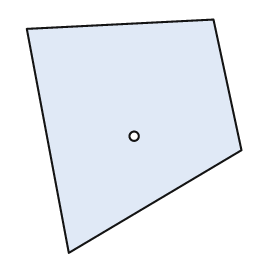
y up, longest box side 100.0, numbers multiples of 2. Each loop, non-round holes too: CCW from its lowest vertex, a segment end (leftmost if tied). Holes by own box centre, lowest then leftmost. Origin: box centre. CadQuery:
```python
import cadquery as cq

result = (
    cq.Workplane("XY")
    .moveTo(-28.0, -50.0)
    .lineTo(46.0, -6.0)
    .lineTo(34.0, 50.0)
    .lineTo(-46.0, 46.0)
    .close()
    .moveTo(0.0, 0.0)
    .circle(2.0)
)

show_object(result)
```